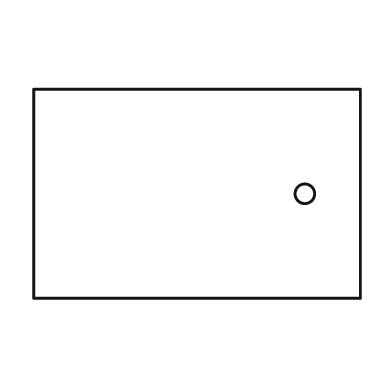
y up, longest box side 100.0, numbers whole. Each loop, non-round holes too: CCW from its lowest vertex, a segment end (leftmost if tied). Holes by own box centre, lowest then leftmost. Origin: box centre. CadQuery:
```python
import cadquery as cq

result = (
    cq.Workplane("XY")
    .moveTo(-50.0, -32.0)
    .lineTo(50.0, -32.0)
    .lineTo(50.0, 32.0)
    .lineTo(-50.0, 32.0)
    .close()
    .moveTo(33.0, 0.0)
    .circle(3.0)
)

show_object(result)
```